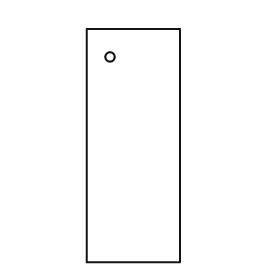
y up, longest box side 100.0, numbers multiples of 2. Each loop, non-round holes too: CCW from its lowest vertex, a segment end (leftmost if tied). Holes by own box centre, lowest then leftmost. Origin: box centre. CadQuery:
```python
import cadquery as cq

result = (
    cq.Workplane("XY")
    .moveTo(-20.0, -50.0)
    .lineTo(20.0, -50.0)
    .lineTo(20.0, 50.0)
    .lineTo(-20.0, 50.0)
    .close()
    .moveTo(-10.0, 38.0)
    .circle(2.0)
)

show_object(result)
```